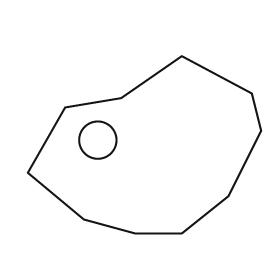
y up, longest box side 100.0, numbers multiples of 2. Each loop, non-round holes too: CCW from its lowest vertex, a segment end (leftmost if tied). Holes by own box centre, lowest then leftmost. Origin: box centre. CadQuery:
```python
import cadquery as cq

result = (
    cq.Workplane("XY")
    .moveTo(-4.0, -38.0)
    .lineTo(16.0, -38.0)
    .lineTo(36.0, -22.0)
    .lineTo(50.0, 6.0)
    .lineTo(46.0, 22.0)
    .lineTo(16.0, 38.0)
    .lineTo(-10.0, 20.0)
    .lineTo(-34.0, 16.0)
    .lineTo(-50.0, -12.0)
    .lineTo(-26.0, -32.0)
    .close()
    .moveTo(-20.0, 2.0)
    .circle(8.0)
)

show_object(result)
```